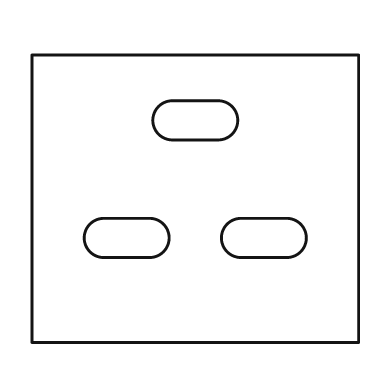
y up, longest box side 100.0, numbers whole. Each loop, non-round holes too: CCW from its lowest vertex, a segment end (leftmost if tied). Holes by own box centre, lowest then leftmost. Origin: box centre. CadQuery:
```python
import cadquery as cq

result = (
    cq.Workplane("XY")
    .moveTo(-50.0, -44.0)
    .lineTo(50.0, -44.0)
    .lineTo(50.0, 44.0)
    .lineTo(-50.0, 44.0)
    .close()
    .moveTo(-28.0, -18.0)
    .lineTo(-14.0, -18.0)
    .threePointArc((-8.0, -12.0), (-14.0, -6.0))
    .lineTo(-28.0, -6.0)
    .threePointArc((-34.0, -12.0), (-28.0, -18.0))
    .close()
    .moveTo(14.0, -18.0)
    .lineTo(28.0, -18.0)
    .threePointArc((34.0, -12.0), (28.0, -6.0))
    .lineTo(14.0, -6.0)
    .threePointArc((8.0, -12.0), (14.0, -18.0))
    .close()
    .moveTo(-7.0, 18.0)
    .lineTo(7.0, 18.0)
    .threePointArc((13.0, 24.0), (7.0, 30.0))
    .lineTo(-7.0, 30.0)
    .threePointArc((-13.0, 24.0), (-7.0, 18.0))
    .close()
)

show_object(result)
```